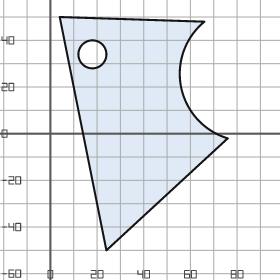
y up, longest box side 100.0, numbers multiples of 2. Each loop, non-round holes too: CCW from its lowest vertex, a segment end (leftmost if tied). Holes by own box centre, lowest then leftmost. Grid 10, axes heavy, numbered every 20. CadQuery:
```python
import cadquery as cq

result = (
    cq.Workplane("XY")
    .moveTo(24.0, -50.0)
    .lineTo(76.0, -2.0)
    .threePointArc((56.0, 20.0), (66.0, 48.0))
    .lineTo(4.0, 50.0)
    .close()
    .moveTo(18.0, 34.0)
    .circle(6.0)
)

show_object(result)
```